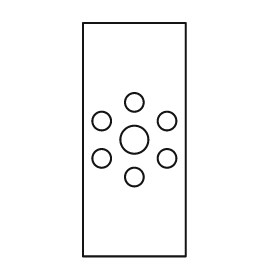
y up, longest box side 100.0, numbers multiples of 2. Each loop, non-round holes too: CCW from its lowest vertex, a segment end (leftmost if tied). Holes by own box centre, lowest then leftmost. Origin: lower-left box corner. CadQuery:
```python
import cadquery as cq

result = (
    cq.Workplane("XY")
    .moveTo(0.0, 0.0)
    .lineTo(44.0, 0.0)
    .lineTo(44.0, 100.0)
    .lineTo(0.0, 100.0)
    .close()
    .moveTo(22.0, 34.0)
    .circle(4.0)
    .moveTo(8.0, 42.0)
    .circle(4.0)
    .moveTo(36.0, 42.0)
    .circle(4.0)
    .moveTo(22.0, 50.0)
    .circle(6.0)
    .moveTo(8.0, 58.0)
    .circle(4.0)
    .moveTo(36.0, 58.0)
    .circle(4.0)
    .moveTo(22.0, 66.0)
    .circle(4.0)
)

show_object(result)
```